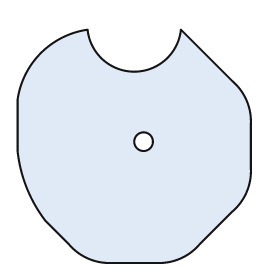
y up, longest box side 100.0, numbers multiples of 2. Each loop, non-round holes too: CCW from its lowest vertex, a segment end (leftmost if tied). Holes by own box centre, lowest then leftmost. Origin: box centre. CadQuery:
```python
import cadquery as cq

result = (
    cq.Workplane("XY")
    .moveTo(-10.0, -50.0)
    .lineTo(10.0, -50.0)
    .threePointArc((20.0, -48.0), (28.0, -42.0))
    .lineTo(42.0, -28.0)
    .threePointArc((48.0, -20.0), (50.0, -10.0))
    .lineTo(50.0, 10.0)
    .threePointArc((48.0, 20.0), (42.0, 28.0))
    .lineTo(20.0, 50.0)
    .threePointArc((0.0, 32.0), (-20.0, 50.0))
    .threePointArc((-40.0, 40.0), (-50.0, 20.0))
    .lineTo(-50.0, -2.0)
    .threePointArc((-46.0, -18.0), (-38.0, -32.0))
    .lineTo(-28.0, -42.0)
    .threePointArc((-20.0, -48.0), (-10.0, -50.0))
    .close()
    .moveTo(4.0, 2.0)
    .circle(4.0)
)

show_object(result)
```